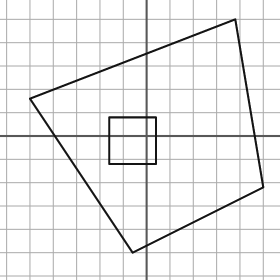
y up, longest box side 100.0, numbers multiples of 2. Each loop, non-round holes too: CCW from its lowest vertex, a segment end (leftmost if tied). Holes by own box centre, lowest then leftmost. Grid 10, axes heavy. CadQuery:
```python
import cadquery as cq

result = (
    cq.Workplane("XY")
    .moveTo(-6.0, -50.0)
    .lineTo(50.0, -22.0)
    .lineTo(38.0, 50.0)
    .lineTo(-50.0, 16.0)
    .close()
    .moveTo(-16.0, -12.0)
    .lineTo(4.0, -12.0)
    .lineTo(4.0, 8.0)
    .lineTo(-16.0, 8.0)
    .close()
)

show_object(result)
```